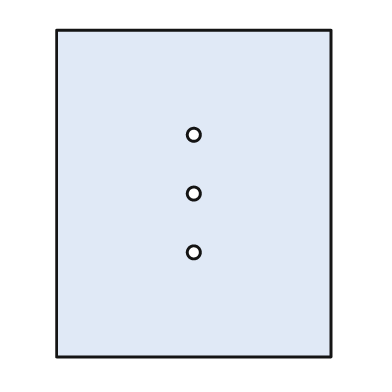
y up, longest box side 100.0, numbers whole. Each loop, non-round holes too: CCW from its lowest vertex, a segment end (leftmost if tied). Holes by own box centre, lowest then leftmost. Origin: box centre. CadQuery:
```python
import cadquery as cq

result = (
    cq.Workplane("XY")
    .moveTo(-42.0, -50.0)
    .lineTo(42.0, -50.0)
    .lineTo(42.0, 50.0)
    .lineTo(-42.0, 50.0)
    .close()
    .moveTo(0.0, -18.0)
    .circle(2.0)
    .moveTo(0.0, 0.0)
    .circle(2.0)
    .moveTo(0.0, 18.0)
    .circle(2.0)
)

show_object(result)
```